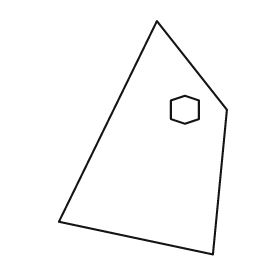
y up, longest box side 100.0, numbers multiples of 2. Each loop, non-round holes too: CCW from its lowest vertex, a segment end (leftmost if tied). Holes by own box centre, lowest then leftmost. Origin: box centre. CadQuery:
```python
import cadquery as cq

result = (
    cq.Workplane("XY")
    .moveTo(30.0, -50.0)
    .lineTo(36.0, 12.0)
    .lineTo(6.0, 50.0)
    .lineTo(-36.0, -36.0)
    .close()
    .moveTo(18.0, 6.0)
    .lineTo(24.0, 8.0)
    .lineTo(24.0, 16.0)
    .lineTo(18.0, 18.0)
    .lineTo(12.0, 16.0)
    .lineTo(12.0, 8.0)
    .close()
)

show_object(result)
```